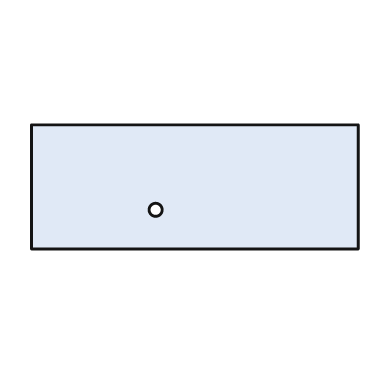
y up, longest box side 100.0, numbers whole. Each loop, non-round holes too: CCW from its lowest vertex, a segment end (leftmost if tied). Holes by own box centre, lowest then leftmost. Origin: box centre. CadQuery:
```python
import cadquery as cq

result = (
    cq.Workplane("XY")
    .moveTo(-50.0, -19.0)
    .lineTo(50.0, -19.0)
    .lineTo(50.0, 19.0)
    .lineTo(-50.0, 19.0)
    .close()
    .moveTo(-12.0, -7.0)
    .circle(2.0)
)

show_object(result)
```